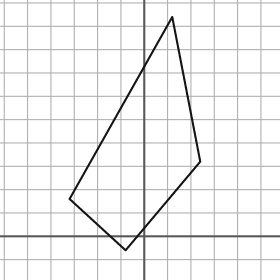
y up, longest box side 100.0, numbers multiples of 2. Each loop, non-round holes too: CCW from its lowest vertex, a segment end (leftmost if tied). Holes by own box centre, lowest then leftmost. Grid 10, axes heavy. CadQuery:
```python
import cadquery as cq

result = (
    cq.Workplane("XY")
    .moveTo(-8.0, -6.0)
    .lineTo(24.0, 32.0)
    .lineTo(12.0, 94.0)
    .lineTo(-32.0, 16.0)
    .close()
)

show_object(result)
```